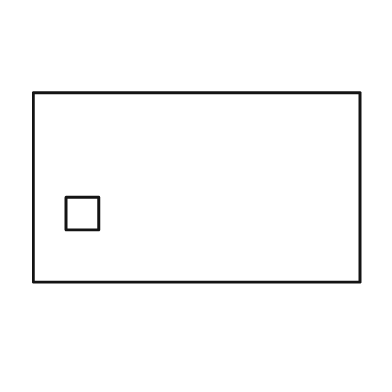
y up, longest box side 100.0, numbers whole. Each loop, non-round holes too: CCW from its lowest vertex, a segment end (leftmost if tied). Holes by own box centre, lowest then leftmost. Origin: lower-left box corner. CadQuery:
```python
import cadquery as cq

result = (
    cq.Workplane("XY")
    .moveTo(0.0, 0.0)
    .lineTo(100.0, 0.0)
    .lineTo(100.0, 58.0)
    .lineTo(0.0, 58.0)
    .close()
    .moveTo(10.0, 16.0)
    .lineTo(20.0, 16.0)
    .lineTo(20.0, 26.0)
    .lineTo(10.0, 26.0)
    .close()
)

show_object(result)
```